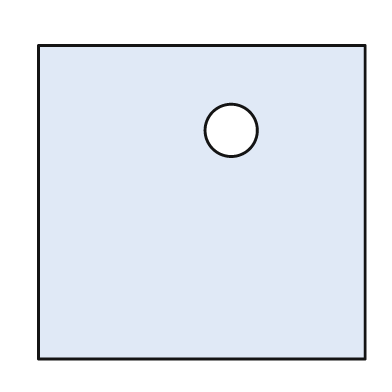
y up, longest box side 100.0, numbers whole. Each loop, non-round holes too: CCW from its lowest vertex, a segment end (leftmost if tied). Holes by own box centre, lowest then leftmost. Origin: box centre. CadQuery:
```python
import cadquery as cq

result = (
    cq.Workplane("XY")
    .moveTo(-50.0, -48.0)
    .lineTo(50.0, -48.0)
    .lineTo(50.0, 48.0)
    .lineTo(-50.0, 48.0)
    .close()
    .moveTo(9.0, 22.0)
    .circle(8.0)
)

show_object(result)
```